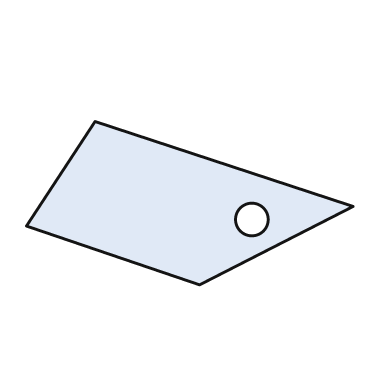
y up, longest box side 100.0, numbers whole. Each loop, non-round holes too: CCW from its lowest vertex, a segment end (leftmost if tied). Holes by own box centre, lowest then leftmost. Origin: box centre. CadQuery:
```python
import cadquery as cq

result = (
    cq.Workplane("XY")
    .moveTo(3.0, -25.0)
    .lineTo(50.0, -1.0)
    .lineTo(-29.0, 25.0)
    .lineTo(-50.0, -7.0)
    .close()
    .moveTo(19.0, -5.0)
    .circle(5.0)
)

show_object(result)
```